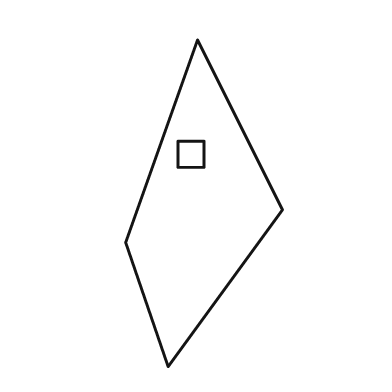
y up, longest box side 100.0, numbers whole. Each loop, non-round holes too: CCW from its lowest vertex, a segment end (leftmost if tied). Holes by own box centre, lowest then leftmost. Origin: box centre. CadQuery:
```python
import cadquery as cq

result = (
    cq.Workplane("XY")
    .moveTo(-11.0, -50.0)
    .lineTo(24.0, -2.0)
    .lineTo(-2.0, 50.0)
    .lineTo(-24.0, -12.0)
    .close()
    .moveTo(-8.0, 11.0)
    .lineTo(0.0, 11.0)
    .lineTo(0.0, 19.0)
    .lineTo(-8.0, 19.0)
    .close()
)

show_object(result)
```